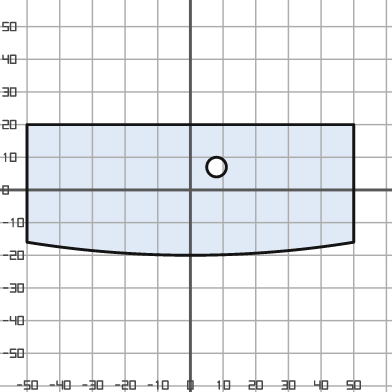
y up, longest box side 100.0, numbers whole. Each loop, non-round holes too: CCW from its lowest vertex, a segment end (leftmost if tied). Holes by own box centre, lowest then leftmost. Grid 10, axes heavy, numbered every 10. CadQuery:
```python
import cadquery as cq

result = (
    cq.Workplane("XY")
    .moveTo(-50.0, -16.0)
    .threePointArc((0.0, -20.0), (50.0, -16.0))
    .lineTo(50.0, 20.0)
    .lineTo(-50.0, 20.0)
    .close()
    .moveTo(8.0, 7.0)
    .circle(3.0)
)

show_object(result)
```